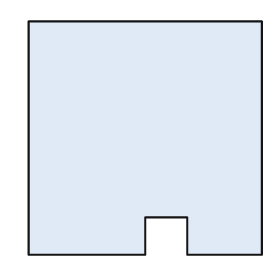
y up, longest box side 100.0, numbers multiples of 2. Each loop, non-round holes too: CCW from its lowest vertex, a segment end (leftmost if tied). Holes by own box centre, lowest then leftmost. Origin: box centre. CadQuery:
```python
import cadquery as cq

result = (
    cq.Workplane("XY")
    .moveTo(-50.0, -50.0)
    .lineTo(0.0, -50.0)
    .lineTo(0.0, -34.0)
    .lineTo(18.0, -34.0)
    .lineTo(18.0, -50.0)
    .lineTo(50.0, -50.0)
    .lineTo(50.0, 50.0)
    .lineTo(-50.0, 50.0)
    .close()
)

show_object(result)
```